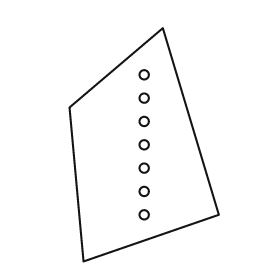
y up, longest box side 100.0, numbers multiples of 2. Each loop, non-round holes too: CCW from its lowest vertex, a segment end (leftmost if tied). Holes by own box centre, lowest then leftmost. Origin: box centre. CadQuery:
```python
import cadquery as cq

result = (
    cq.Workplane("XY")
    .moveTo(-26.0, -50.0)
    .lineTo(32.0, -30.0)
    .lineTo(8.0, 50.0)
    .lineTo(-32.0, 16.0)
    .close()
    .moveTo(0.0, -30.0)
    .circle(2.0)
    .moveTo(0.0, -20.0)
    .circle(2.0)
    .moveTo(0.0, -10.0)
    .circle(2.0)
    .moveTo(0.0, 0.0)
    .circle(2.0)
    .moveTo(0.0, 10.0)
    .circle(2.0)
    .moveTo(0.0, 20.0)
    .circle(2.0)
    .moveTo(0.0, 30.0)
    .circle(2.0)
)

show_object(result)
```